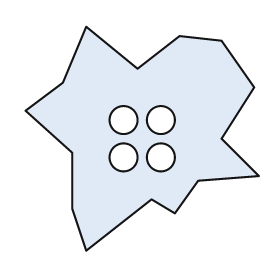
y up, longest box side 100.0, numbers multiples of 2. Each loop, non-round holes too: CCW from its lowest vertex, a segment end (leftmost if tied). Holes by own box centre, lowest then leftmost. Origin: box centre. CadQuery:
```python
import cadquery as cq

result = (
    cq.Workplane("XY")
    .moveTo(-24.0, -48.0)
    .lineTo(4.0, -26.0)
    .lineTo(14.0, -32.0)
    .lineTo(24.0, -18.0)
    .lineTo(50.0, -16.0)
    .lineTo(34.0, 0.0)
    .lineTo(48.0, 22.0)
    .lineTo(34.0, 42.0)
    .lineTo(16.0, 44.0)
    .lineTo(-2.0, 30.0)
    .lineTo(-24.0, 48.0)
    .lineTo(-34.0, 24.0)
    .lineTo(-50.0, 12.0)
    .lineTo(-30.0, -6.0)
    .lineTo(-30.0, -30.0)
    .close()
    .moveTo(-8.0, -8.0)
    .circle(6.0)
    .moveTo(8.0, -8.0)
    .circle(6.0)
    .moveTo(-8.0, 8.0)
    .circle(6.0)
    .moveTo(8.0, 8.0)
    .circle(6.0)
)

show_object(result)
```